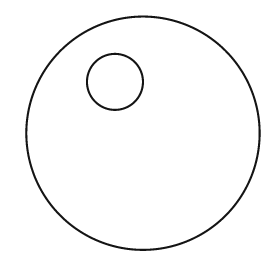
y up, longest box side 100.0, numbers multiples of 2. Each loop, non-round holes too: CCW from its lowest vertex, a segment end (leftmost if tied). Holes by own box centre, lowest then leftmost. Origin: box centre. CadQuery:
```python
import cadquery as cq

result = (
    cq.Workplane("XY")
    .moveTo(0.0, 0.0)
    .circle(50.0)
    .moveTo(-12.0, 22.0)
    .circle(12.0)
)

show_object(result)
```